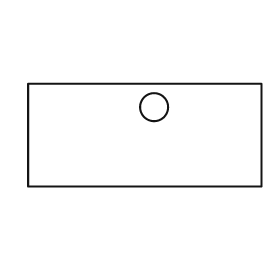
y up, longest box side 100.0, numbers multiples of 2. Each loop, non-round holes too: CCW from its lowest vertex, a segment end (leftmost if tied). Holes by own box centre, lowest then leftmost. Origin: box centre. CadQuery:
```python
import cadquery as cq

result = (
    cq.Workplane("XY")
    .moveTo(-50.0, -22.0)
    .lineTo(50.0, -22.0)
    .lineTo(50.0, 22.0)
    .lineTo(-50.0, 22.0)
    .close()
    .moveTo(4.0, 12.0)
    .circle(6.0)
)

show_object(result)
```